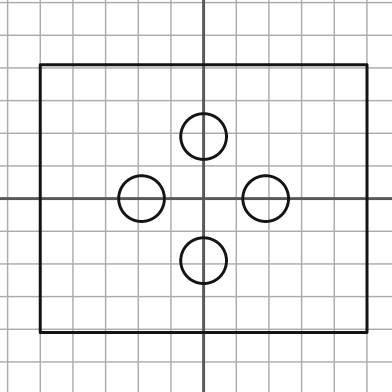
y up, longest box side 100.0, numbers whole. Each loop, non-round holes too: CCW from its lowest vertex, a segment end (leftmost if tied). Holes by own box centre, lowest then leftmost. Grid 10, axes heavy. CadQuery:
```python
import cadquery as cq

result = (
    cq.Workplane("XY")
    .moveTo(-50.0, -41.0)
    .lineTo(50.0, -41.0)
    .lineTo(50.0, 41.0)
    .lineTo(-50.0, 41.0)
    .close()
    .moveTo(0.0, -19.0)
    .circle(7.0)
    .moveTo(-19.0, 0.0)
    .circle(7.0)
    .moveTo(19.0, 0.0)
    .circle(7.0)
    .moveTo(0.0, 19.0)
    .circle(7.0)
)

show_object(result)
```